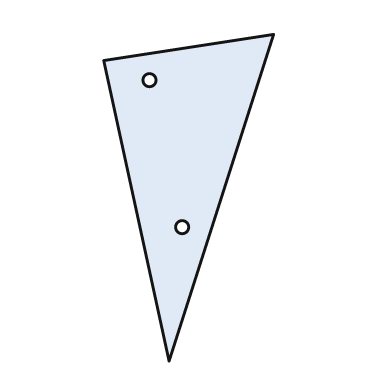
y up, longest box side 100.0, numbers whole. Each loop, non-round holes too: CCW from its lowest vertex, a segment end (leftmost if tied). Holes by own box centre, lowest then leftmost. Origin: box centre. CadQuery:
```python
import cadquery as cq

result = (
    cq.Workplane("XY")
    .moveTo(-6.0, -50.0)
    .lineTo(26.0, 50.0)
    .lineTo(-26.0, 42.0)
    .close()
    .moveTo(-2.0, -9.0)
    .circle(2.0)
    .moveTo(-12.0, 36.0)
    .circle(2.0)
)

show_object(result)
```